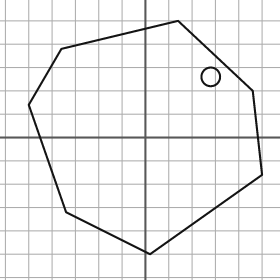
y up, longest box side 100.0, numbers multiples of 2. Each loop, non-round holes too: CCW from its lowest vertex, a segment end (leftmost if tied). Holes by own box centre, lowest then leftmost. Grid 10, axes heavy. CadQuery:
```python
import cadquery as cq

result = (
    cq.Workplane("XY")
    .moveTo(2.0, -50.0)
    .lineTo(50.0, -16.0)
    .lineTo(46.0, 20.0)
    .lineTo(14.0, 50.0)
    .lineTo(-36.0, 38.0)
    .lineTo(-50.0, 14.0)
    .lineTo(-34.0, -32.0)
    .close()
    .moveTo(28.0, 26.0)
    .circle(4.0)
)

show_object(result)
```